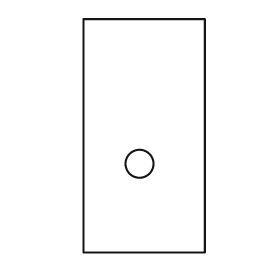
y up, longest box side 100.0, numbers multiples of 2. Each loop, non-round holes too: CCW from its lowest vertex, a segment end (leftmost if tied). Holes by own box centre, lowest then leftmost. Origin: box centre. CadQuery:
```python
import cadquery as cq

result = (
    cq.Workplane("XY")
    .moveTo(-26.0, -50.0)
    .lineTo(26.0, -50.0)
    .lineTo(26.0, 50.0)
    .lineTo(-26.0, 50.0)
    .close()
    .moveTo(-2.0, -12.0)
    .circle(6.0)
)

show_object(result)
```